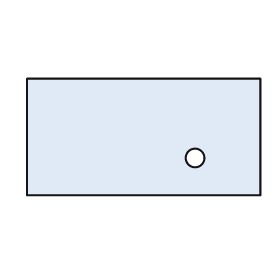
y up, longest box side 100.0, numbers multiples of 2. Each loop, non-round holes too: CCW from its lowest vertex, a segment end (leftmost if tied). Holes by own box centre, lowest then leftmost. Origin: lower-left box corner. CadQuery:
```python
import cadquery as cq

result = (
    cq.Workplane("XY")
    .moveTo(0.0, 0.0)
    .lineTo(100.0, 0.0)
    .lineTo(100.0, 50.0)
    .lineTo(0.0, 50.0)
    .close()
    .moveTo(72.0, 16.0)
    .circle(4.0)
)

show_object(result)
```